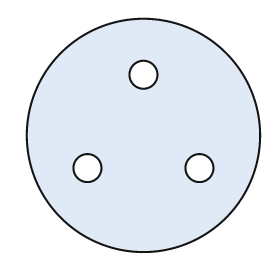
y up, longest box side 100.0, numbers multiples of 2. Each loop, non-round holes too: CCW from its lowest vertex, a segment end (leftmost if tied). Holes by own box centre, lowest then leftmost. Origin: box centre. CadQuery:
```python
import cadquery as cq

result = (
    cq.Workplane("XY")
    .moveTo(0.0, 0.0)
    .circle(50.0)
    .moveTo(-24.0, -14.0)
    .circle(6.0)
    .moveTo(24.0, -14.0)
    .circle(6.0)
    .moveTo(0.0, 26.0)
    .circle(6.0)
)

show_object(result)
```